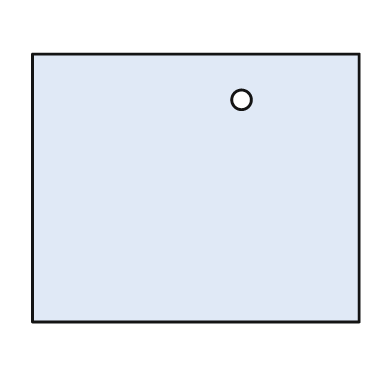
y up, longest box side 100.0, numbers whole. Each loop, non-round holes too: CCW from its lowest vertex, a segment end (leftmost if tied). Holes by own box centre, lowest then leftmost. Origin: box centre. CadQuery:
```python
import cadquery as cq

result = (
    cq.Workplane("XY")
    .moveTo(-50.0, -41.0)
    .lineTo(50.0, -41.0)
    .lineTo(50.0, 41.0)
    .lineTo(-50.0, 41.0)
    .close()
    .moveTo(14.0, 27.0)
    .circle(3.0)
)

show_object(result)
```